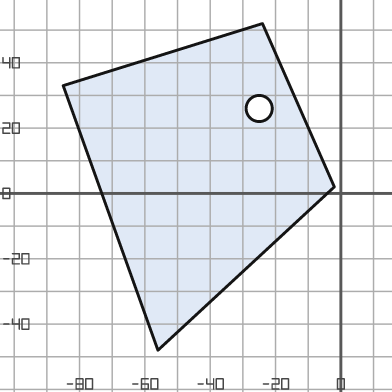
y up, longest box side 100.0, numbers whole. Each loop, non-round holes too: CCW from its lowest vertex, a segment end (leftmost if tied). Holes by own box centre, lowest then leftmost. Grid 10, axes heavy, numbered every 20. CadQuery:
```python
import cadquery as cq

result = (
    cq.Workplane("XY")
    .moveTo(-56.0, -48.0)
    .lineTo(-2.0, 2.0)
    .lineTo(-24.0, 52.0)
    .lineTo(-85.0, 33.0)
    .close()
    .moveTo(-25.0, 26.0)
    .circle(4.0)
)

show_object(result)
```